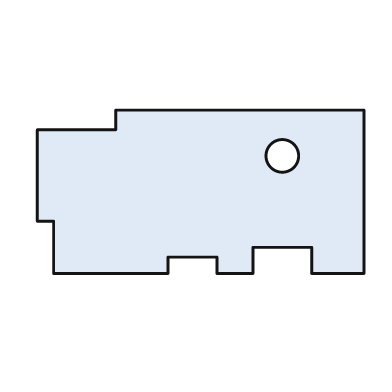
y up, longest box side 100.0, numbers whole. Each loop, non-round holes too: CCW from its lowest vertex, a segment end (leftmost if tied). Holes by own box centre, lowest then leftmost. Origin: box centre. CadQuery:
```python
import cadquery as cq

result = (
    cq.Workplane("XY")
    .moveTo(-45.0, -25.0)
    .lineTo(-10.0, -25.0)
    .lineTo(-10.0, -20.0)
    .lineTo(5.0, -20.0)
    .lineTo(5.0, -25.0)
    .lineTo(16.0, -25.0)
    .lineTo(16.0, -17.0)
    .lineTo(34.0, -17.0)
    .lineTo(34.0, -25.0)
    .lineTo(50.0, -25.0)
    .lineTo(50.0, 25.0)
    .lineTo(-26.0, 25.0)
    .lineTo(-26.0, 19.0)
    .lineTo(-50.0, 19.0)
    .lineTo(-50.0, -9.0)
    .lineTo(-45.0, -9.0)
    .close()
    .moveTo(25.0, 11.0)
    .circle(5.0)
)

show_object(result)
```